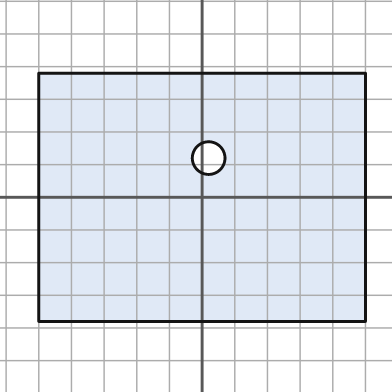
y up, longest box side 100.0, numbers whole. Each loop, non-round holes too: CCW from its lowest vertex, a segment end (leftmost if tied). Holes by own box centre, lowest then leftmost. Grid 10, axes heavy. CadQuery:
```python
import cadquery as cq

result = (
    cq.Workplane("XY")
    .moveTo(-50.0, -38.0)
    .lineTo(50.0, -38.0)
    .lineTo(50.0, 38.0)
    .lineTo(-50.0, 38.0)
    .close()
    .moveTo(2.0, 12.0)
    .circle(5.0)
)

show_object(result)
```